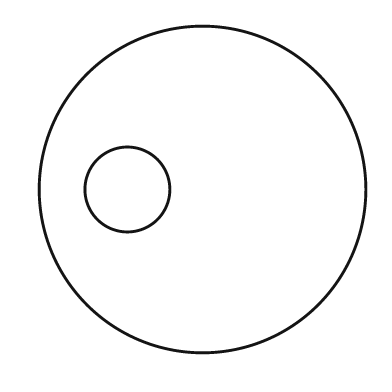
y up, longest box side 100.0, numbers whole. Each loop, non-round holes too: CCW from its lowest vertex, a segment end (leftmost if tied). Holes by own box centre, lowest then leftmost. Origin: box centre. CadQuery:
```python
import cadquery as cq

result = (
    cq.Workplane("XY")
    .moveTo(0.0, 0.0)
    .circle(50.0)
    .moveTo(-23.0, 0.0)
    .circle(13.0)
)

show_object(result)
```